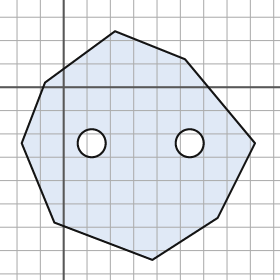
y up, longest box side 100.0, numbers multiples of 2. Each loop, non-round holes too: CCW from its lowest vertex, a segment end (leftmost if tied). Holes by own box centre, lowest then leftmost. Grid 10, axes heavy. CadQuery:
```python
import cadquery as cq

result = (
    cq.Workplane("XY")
    .moveTo(38.0, -74.0)
    .lineTo(66.0, -56.0)
    .lineTo(82.0, -24.0)
    .lineTo(52.0, 12.0)
    .lineTo(22.0, 24.0)
    .lineTo(-8.0, 2.0)
    .lineTo(-18.0, -24.0)
    .lineTo(-4.0, -58.0)
    .close()
    .moveTo(12.0, -24.0)
    .circle(6.0)
    .moveTo(54.0, -24.0)
    .circle(6.0)
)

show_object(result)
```